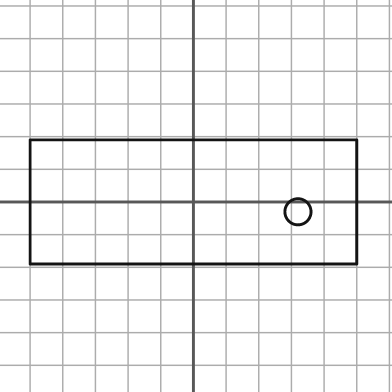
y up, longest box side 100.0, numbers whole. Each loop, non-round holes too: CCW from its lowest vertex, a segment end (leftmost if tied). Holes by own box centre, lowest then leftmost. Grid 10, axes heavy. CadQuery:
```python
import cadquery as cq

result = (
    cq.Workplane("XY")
    .moveTo(-50.0, -19.0)
    .lineTo(50.0, -19.0)
    .lineTo(50.0, 19.0)
    .lineTo(-50.0, 19.0)
    .close()
    .moveTo(32.0, -3.0)
    .circle(4.0)
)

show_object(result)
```